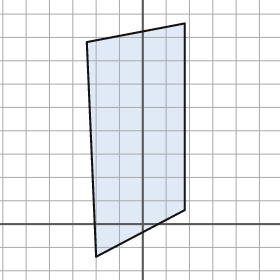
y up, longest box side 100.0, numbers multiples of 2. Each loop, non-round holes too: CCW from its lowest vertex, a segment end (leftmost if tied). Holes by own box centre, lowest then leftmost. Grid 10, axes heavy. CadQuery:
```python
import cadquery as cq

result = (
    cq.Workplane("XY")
    .moveTo(-20.0, -14.0)
    .lineTo(18.0, 6.0)
    .lineTo(18.0, 86.0)
    .lineTo(-24.0, 78.0)
    .close()
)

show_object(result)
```